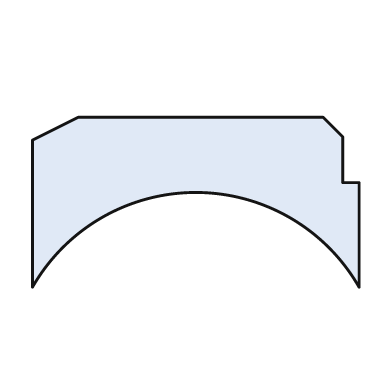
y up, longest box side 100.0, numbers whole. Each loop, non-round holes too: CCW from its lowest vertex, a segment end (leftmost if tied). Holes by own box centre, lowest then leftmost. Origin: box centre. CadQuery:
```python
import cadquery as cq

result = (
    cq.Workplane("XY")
    .moveTo(-50.0, -26.0)
    .threePointArc((0.0, 3.0), (50.0, -26.0))
    .lineTo(50.0, 6.0)
    .lineTo(45.0, 6.0)
    .lineTo(45.0, 20.0)
    .lineTo(39.0, 26.0)
    .lineTo(-36.0, 26.0)
    .lineTo(-50.0, 19.0)
    .close()
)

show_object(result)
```